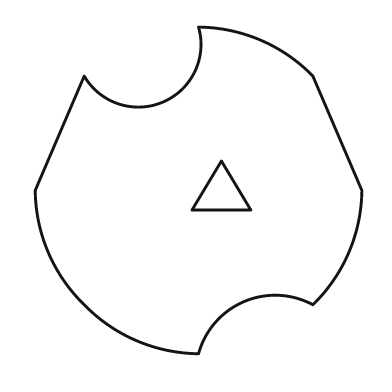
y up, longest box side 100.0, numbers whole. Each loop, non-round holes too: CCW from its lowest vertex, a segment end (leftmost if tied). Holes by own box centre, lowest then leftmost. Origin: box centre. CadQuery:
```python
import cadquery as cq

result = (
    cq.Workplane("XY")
    .moveTo(0.0, -50.0)
    .threePointArc((14.0, -34.0), (35.0, -35.0))
    .threePointArc((46.0, -19.0), (50.0, 0.0))
    .lineTo(35.0, 35.0)
    .threePointArc((19.0, 46.0), (0.0, 50.0))
    .threePointArc((-11.0, 27.0), (-35.0, 35.0))
    .lineTo(-50.0, 0.0)
    .threePointArc((-46.0, -19.0), (-35.0, -35.0))
    .threePointArc((-19.0, -46.0), (0.0, -50.0))
    .close()
    .moveTo(-2.0, -6.0)
    .lineTo(16.0, -6.0)
    .lineTo(7.0, 9.0)
    .close()
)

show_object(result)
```